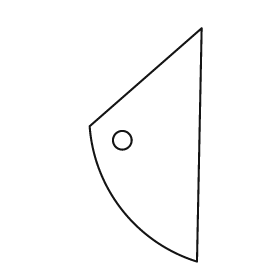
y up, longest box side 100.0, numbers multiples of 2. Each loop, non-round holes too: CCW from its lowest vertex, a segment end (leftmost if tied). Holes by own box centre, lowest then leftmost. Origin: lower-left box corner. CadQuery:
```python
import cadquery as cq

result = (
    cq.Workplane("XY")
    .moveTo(46.0, 0.0)
    .lineTo(48.0, 100.0)
    .lineTo(0.0, 58.0)
    .threePointArc((14.0, 22.0), (46.0, 0.0))
    .close()
    .moveTo(14.0, 52.0)
    .circle(4.0)
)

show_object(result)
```